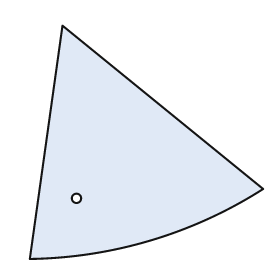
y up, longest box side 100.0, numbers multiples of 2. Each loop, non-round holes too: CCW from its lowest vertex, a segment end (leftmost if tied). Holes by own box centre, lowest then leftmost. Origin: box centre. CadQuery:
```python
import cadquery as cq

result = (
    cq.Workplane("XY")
    .moveTo(-50.0, -50.0)
    .threePointArc((2.0, -42.0), (50.0, -20.0))
    .lineTo(-36.0, 50.0)
    .close()
    .moveTo(-30.0, -24.0)
    .circle(2.0)
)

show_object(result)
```